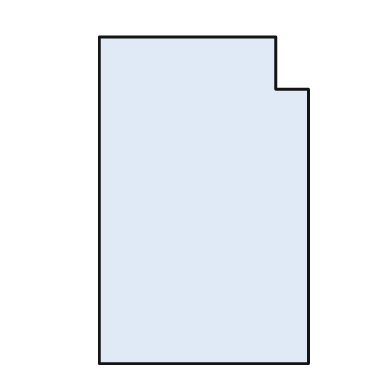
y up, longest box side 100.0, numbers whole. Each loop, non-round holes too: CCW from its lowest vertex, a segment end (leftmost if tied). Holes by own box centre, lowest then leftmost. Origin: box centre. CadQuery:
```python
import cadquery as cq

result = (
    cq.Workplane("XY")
    .moveTo(-32.0, -50.0)
    .lineTo(32.0, -50.0)
    .lineTo(32.0, 34.0)
    .lineTo(22.0, 34.0)
    .lineTo(22.0, 50.0)
    .lineTo(-32.0, 50.0)
    .close()
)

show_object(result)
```